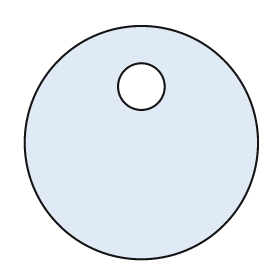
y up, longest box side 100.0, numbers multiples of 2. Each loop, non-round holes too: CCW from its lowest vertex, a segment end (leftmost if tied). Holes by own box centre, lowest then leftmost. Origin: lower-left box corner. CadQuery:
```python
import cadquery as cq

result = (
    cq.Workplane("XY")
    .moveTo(50.0, 50.0)
    .circle(50.0)
    .moveTo(50.0, 74.0)
    .circle(10.0)
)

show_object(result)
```